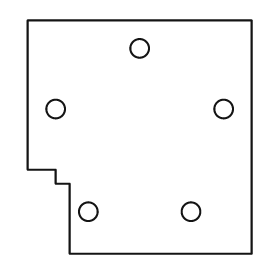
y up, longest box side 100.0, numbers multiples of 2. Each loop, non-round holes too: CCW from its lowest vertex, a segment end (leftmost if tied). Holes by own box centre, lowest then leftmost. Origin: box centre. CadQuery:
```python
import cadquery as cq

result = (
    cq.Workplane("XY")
    .moveTo(-30.0, -50.0)
    .lineTo(48.0, -50.0)
    .lineTo(48.0, 50.0)
    .lineTo(-48.0, 50.0)
    .lineTo(-48.0, -14.0)
    .lineTo(-36.0, -14.0)
    .lineTo(-36.0, -20.0)
    .lineTo(-30.0, -20.0)
    .close()
    .moveTo(-22.0, -32.0)
    .circle(4.0)
    .moveTo(22.0, -32.0)
    .circle(4.0)
    .moveTo(-36.0, 12.0)
    .circle(4.0)
    .moveTo(36.0, 12.0)
    .circle(4.0)
    .moveTo(0.0, 38.0)
    .circle(4.0)
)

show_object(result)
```